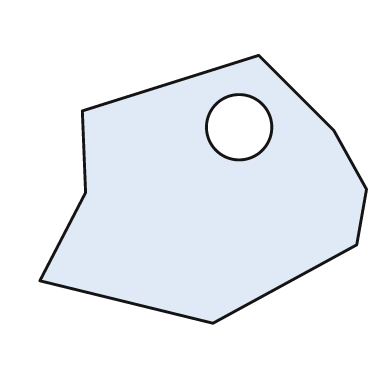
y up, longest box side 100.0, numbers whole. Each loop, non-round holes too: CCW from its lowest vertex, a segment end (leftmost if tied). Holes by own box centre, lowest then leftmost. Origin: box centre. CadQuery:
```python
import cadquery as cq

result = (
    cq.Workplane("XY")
    .moveTo(3.0, -41.0)
    .lineTo(47.0, -17.0)
    .lineTo(50.0, 0.0)
    .lineTo(40.0, 18.0)
    .lineTo(17.0, 41.0)
    .lineTo(-37.0, 24.0)
    .lineTo(-36.0, -1.0)
    .lineTo(-50.0, -28.0)
    .close()
    .moveTo(11.0, 19.0)
    .circle(10.0)
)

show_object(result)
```